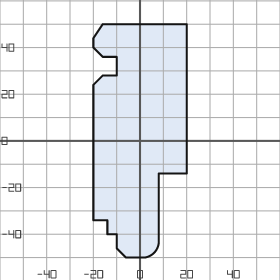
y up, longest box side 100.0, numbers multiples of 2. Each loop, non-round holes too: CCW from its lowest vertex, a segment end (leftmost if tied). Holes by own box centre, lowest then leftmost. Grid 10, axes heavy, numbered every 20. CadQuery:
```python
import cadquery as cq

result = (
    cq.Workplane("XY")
    .moveTo(-6.0, -50.0)
    .lineTo(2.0, -50.0)
    .threePointArc((6.0, -48.0), (8.0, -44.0))
    .lineTo(8.0, -14.0)
    .lineTo(20.0, -14.0)
    .lineTo(20.0, 50.0)
    .lineTo(-16.0, 50.0)
    .lineTo(-20.0, 44.0)
    .lineTo(-20.0, 40.0)
    .lineTo(-16.0, 36.0)
    .lineTo(-10.0, 36.0)
    .lineTo(-10.0, 28.0)
    .lineTo(-16.0, 28.0)
    .lineTo(-20.0, 24.0)
    .lineTo(-20.0, -34.0)
    .lineTo(-14.0, -34.0)
    .lineTo(-14.0, -40.0)
    .lineTo(-10.0, -40.0)
    .lineTo(-10.0, -46.0)
    .close()
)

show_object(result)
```